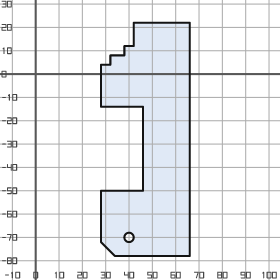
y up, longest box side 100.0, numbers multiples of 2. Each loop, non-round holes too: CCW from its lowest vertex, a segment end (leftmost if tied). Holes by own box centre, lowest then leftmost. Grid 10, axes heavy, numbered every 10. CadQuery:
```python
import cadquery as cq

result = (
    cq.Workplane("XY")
    .moveTo(34.0, -78.0)
    .lineTo(66.0, -78.0)
    .lineTo(66.0, 22.0)
    .lineTo(42.0, 22.0)
    .lineTo(42.0, 12.0)
    .lineTo(38.0, 12.0)
    .lineTo(38.0, 8.0)
    .lineTo(32.0, 8.0)
    .lineTo(32.0, 4.0)
    .lineTo(28.0, 4.0)
    .lineTo(28.0, -14.0)
    .lineTo(46.0, -14.0)
    .lineTo(46.0, -50.0)
    .lineTo(28.0, -50.0)
    .lineTo(28.0, -72.0)
    .close()
    .moveTo(40.0, -70.0)
    .circle(2.0)
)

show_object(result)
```